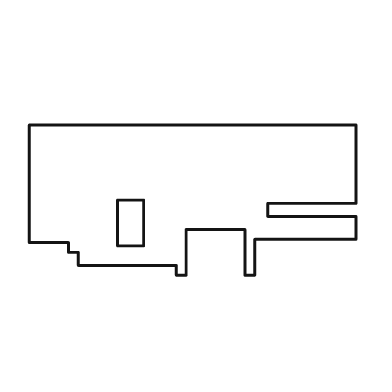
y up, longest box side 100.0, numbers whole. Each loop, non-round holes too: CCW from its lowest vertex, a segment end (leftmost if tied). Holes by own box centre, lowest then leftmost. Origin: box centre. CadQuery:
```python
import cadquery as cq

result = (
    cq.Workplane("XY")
    .moveTo(-5.0, -23.0)
    .lineTo(-2.0, -23.0)
    .lineTo(-2.0, -9.0)
    .lineTo(16.0, -9.0)
    .lineTo(16.0, -23.0)
    .lineTo(19.0, -23.0)
    .lineTo(19.0, -12.0)
    .lineTo(50.0, -12.0)
    .lineTo(50.0, -5.0)
    .lineTo(23.0, -5.0)
    .lineTo(23.0, -1.0)
    .lineTo(50.0, -1.0)
    .lineTo(50.0, 23.0)
    .lineTo(-50.0, 23.0)
    .lineTo(-50.0, -13.0)
    .lineTo(-38.0, -13.0)
    .lineTo(-38.0, -16.0)
    .lineTo(-35.0, -16.0)
    .lineTo(-35.0, -20.0)
    .lineTo(-5.0, -20.0)
    .close()
    .moveTo(-23.0, -14.0)
    .lineTo(-15.0, -14.0)
    .lineTo(-15.0, 0.0)
    .lineTo(-23.0, 0.0)
    .close()
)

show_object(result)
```